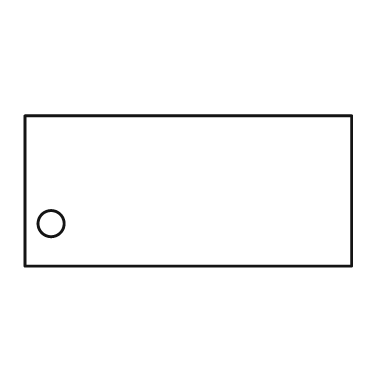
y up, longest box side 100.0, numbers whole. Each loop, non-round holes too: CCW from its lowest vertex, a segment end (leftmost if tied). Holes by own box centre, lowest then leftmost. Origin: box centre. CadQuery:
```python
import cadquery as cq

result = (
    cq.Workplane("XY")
    .moveTo(-50.0, -23.0)
    .lineTo(50.0, -23.0)
    .lineTo(50.0, 23.0)
    .lineTo(-50.0, 23.0)
    .close()
    .moveTo(-42.0, -10.0)
    .circle(4.0)
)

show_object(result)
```